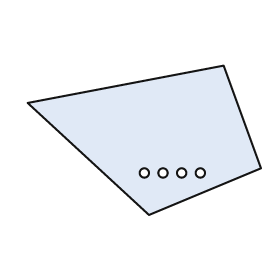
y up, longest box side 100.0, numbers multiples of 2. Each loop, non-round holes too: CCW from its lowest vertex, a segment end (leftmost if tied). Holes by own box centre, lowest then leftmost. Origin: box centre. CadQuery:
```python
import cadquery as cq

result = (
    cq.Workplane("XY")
    .moveTo(2.0, -32.0)
    .lineTo(50.0, -12.0)
    .lineTo(34.0, 32.0)
    .lineTo(-50.0, 16.0)
    .close()
    .moveTo(0.0, -14.0)
    .circle(2.0)
    .moveTo(8.0, -14.0)
    .circle(2.0)
    .moveTo(16.0, -14.0)
    .circle(2.0)
    .moveTo(24.0, -14.0)
    .circle(2.0)
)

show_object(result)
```